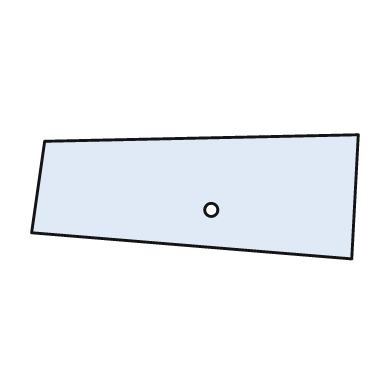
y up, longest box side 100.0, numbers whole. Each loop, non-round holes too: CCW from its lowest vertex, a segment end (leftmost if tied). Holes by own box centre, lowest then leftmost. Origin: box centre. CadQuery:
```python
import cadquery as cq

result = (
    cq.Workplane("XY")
    .moveTo(48.0, -19.0)
    .lineTo(50.0, 19.0)
    .lineTo(-46.0, 17.0)
    .lineTo(-50.0, -11.0)
    .close()
    .moveTo(5.0, -4.0)
    .circle(2.0)
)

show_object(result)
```